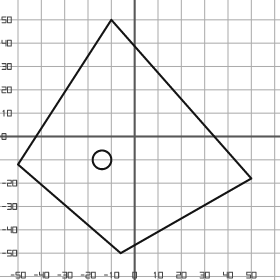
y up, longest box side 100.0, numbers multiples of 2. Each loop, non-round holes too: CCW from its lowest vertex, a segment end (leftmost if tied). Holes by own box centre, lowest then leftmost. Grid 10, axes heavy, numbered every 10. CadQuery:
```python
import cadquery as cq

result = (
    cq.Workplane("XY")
    .moveTo(-6.0, -50.0)
    .lineTo(50.0, -18.0)
    .lineTo(-10.0, 50.0)
    .lineTo(-50.0, -12.0)
    .close()
    .moveTo(-14.0, -10.0)
    .circle(4.0)
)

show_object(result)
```